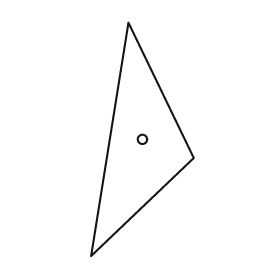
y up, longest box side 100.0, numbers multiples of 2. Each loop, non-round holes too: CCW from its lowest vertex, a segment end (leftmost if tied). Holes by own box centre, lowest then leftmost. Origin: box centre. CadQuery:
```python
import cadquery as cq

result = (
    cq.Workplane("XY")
    .moveTo(-22.0, -50.0)
    .lineTo(22.0, -8.0)
    .lineTo(-6.0, 50.0)
    .close()
    .moveTo(0.0, 0.0)
    .circle(2.0)
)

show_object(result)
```